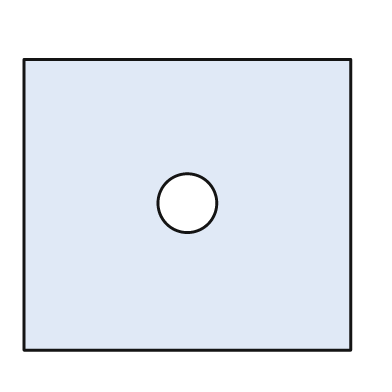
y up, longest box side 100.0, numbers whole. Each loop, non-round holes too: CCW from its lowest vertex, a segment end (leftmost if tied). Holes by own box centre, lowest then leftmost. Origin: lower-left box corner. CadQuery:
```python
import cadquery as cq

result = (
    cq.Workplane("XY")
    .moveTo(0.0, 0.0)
    .lineTo(100.0, 0.0)
    .lineTo(100.0, 89.0)
    .lineTo(0.0, 89.0)
    .close()
    .moveTo(50.0, 45.0)
    .circle(9.0)
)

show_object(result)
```